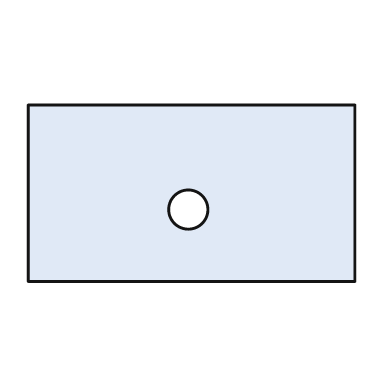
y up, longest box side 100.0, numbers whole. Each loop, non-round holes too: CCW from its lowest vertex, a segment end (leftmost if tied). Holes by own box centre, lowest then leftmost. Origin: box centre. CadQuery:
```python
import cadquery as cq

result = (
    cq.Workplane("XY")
    .moveTo(-50.0, -27.0)
    .lineTo(50.0, -27.0)
    .lineTo(50.0, 27.0)
    .lineTo(-50.0, 27.0)
    .close()
    .moveTo(-1.0, -5.0)
    .circle(6.0)
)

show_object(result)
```